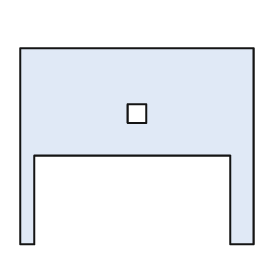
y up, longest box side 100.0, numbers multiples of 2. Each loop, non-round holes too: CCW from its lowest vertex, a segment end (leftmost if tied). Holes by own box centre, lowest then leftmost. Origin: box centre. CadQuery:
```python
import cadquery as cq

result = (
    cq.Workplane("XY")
    .moveTo(-50.0, -42.0)
    .lineTo(-44.0, -42.0)
    .lineTo(-44.0, -4.0)
    .lineTo(40.0, -4.0)
    .lineTo(40.0, -42.0)
    .lineTo(50.0, -42.0)
    .lineTo(50.0, 42.0)
    .lineTo(-50.0, 42.0)
    .close()
    .moveTo(-4.0, 10.0)
    .lineTo(4.0, 10.0)
    .lineTo(4.0, 18.0)
    .lineTo(-4.0, 18.0)
    .close()
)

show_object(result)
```